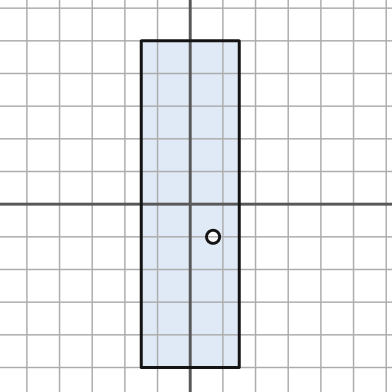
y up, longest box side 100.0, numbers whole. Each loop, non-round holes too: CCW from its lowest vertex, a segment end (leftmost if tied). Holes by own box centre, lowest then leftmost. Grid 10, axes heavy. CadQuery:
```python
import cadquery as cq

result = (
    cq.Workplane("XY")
    .moveTo(-15.0, -50.0)
    .lineTo(15.0, -50.0)
    .lineTo(15.0, 50.0)
    .lineTo(-15.0, 50.0)
    .close()
    .moveTo(7.0, -10.0)
    .circle(2.0)
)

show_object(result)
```